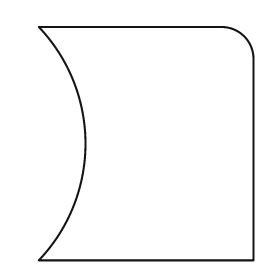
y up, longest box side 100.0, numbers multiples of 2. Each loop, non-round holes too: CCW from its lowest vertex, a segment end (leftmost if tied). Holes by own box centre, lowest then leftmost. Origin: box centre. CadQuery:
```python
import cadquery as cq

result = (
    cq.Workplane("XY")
    .moveTo(-46.0, -50.0)
    .lineTo(46.0, -50.0)
    .lineTo(46.0, 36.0)
    .threePointArc((42.0, 46.0), (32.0, 50.0))
    .lineTo(-46.0, 50.0)
    .threePointArc((-26.0, 0.0), (-46.0, -50.0))
    .close()
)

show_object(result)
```